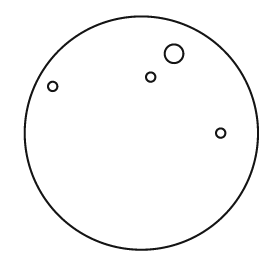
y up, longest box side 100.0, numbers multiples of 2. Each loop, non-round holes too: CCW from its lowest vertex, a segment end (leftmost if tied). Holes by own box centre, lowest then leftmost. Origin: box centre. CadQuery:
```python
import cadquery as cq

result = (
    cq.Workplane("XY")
    .moveTo(0.0, 0.0)
    .circle(50.0)
    .moveTo(34.0, 0.0)
    .circle(2.0)
    .moveTo(-38.0, 20.0)
    .circle(2.0)
    .moveTo(4.0, 24.0)
    .circle(2.0)
    .moveTo(14.0, 34.0)
    .circle(4.0)
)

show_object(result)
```